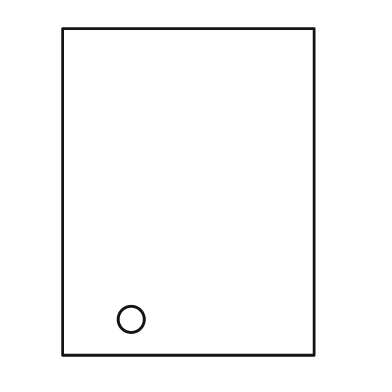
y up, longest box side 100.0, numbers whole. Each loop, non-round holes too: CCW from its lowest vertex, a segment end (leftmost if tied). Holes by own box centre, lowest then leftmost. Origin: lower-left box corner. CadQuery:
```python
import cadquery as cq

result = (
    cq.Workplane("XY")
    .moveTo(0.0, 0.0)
    .lineTo(77.0, 0.0)
    .lineTo(77.0, 100.0)
    .lineTo(0.0, 100.0)
    .close()
    .moveTo(21.0, 11.0)
    .circle(4.0)
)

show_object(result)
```